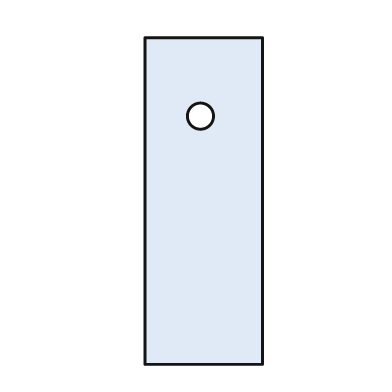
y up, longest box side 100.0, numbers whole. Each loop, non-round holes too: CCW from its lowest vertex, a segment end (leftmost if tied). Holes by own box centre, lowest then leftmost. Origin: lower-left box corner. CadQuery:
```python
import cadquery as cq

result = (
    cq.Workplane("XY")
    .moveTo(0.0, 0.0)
    .lineTo(36.0, 0.0)
    .lineTo(36.0, 100.0)
    .lineTo(0.0, 100.0)
    .close()
    .moveTo(17.0, 76.0)
    .circle(4.0)
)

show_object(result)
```